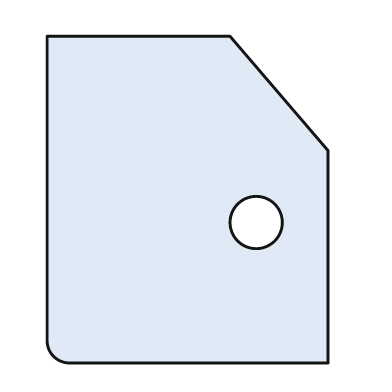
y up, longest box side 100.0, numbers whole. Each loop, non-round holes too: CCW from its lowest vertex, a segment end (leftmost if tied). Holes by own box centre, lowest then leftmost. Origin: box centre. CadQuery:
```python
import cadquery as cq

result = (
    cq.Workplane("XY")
    .moveTo(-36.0, -50.0)
    .lineTo(43.0, -50.0)
    .lineTo(43.0, 15.0)
    .lineTo(13.0, 50.0)
    .lineTo(-43.0, 50.0)
    .lineTo(-43.0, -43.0)
    .threePointArc((-41.0, -48.0), (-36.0, -50.0))
    .close()
    .moveTo(21.0, -7.0)
    .circle(8.0)
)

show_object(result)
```